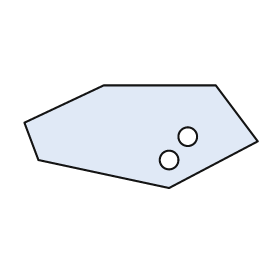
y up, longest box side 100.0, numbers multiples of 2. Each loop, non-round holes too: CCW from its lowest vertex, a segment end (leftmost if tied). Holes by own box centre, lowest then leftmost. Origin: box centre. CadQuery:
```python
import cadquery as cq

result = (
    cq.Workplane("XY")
    .moveTo(12.0, -22.0)
    .lineTo(50.0, -2.0)
    .lineTo(32.0, 22.0)
    .lineTo(-16.0, 22.0)
    .lineTo(-50.0, 6.0)
    .lineTo(-44.0, -10.0)
    .close()
    .moveTo(12.0, -10.0)
    .circle(4.0)
    .moveTo(20.0, 0.0)
    .circle(4.0)
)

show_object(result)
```